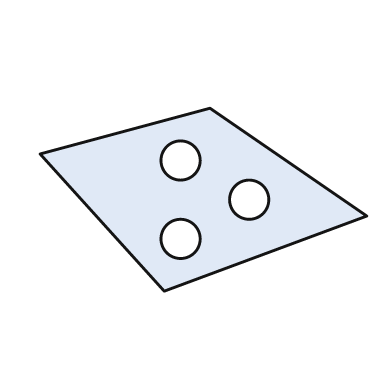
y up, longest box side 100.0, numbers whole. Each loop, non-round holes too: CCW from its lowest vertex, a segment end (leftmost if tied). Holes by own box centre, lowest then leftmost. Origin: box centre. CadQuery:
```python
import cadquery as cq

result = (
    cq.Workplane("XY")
    .moveTo(-12.0, -28.0)
    .lineTo(50.0, -5.0)
    .lineTo(2.0, 28.0)
    .lineTo(-50.0, 14.0)
    .close()
    .moveTo(-7.0, -12.0)
    .circle(6.0)
    .moveTo(14.0, 0.0)
    .circle(6.0)
    .moveTo(-7.0, 12.0)
    .circle(6.0)
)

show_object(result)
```